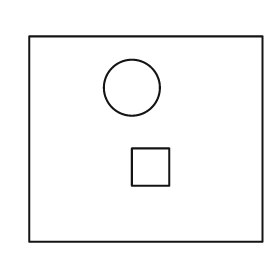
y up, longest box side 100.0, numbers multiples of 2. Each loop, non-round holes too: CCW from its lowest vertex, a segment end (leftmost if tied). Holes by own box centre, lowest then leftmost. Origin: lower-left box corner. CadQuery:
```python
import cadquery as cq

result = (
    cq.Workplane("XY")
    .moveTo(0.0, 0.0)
    .lineTo(100.0, 0.0)
    .lineTo(100.0, 88.0)
    .lineTo(0.0, 88.0)
    .close()
    .moveTo(44.0, 24.0)
    .lineTo(60.0, 24.0)
    .lineTo(60.0, 40.0)
    .lineTo(44.0, 40.0)
    .close()
    .moveTo(44.0, 66.0)
    .circle(12.0)
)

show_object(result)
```